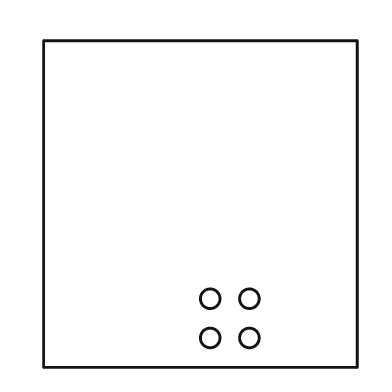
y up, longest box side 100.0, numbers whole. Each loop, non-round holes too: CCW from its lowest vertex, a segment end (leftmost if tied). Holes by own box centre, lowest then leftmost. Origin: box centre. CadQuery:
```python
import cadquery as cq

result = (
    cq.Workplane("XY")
    .moveTo(-48.0, -50.0)
    .lineTo(48.0, -50.0)
    .lineTo(48.0, 50.0)
    .lineTo(-48.0, 50.0)
    .close()
    .moveTo(3.0, -41.0)
    .circle(3.0)
    .moveTo(15.0, -41.0)
    .circle(3.0)
    .moveTo(3.0, -29.0)
    .circle(3.0)
    .moveTo(15.0, -29.0)
    .circle(3.0)
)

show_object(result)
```